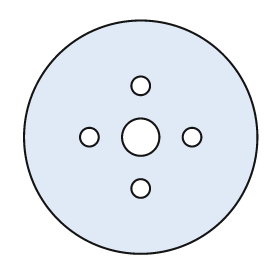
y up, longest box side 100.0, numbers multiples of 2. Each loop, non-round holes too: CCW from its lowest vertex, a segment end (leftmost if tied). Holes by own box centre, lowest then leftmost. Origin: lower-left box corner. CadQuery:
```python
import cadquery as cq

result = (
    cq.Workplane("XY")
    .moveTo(50.0, 50.0)
    .circle(50.0)
    .moveTo(50.0, 28.0)
    .circle(4.0)
    .moveTo(28.0, 50.0)
    .circle(4.0)
    .moveTo(50.0, 50.0)
    .circle(8.0)
    .moveTo(72.0, 50.0)
    .circle(4.0)
    .moveTo(50.0, 72.0)
    .circle(4.0)
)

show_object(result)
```